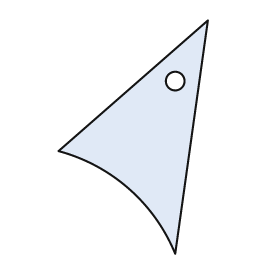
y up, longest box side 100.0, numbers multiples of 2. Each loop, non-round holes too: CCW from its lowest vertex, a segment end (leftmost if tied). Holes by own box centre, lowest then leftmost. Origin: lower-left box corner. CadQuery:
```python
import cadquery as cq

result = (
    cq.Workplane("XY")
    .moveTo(50.0, 0.0)
    .lineTo(64.0, 100.0)
    .lineTo(0.0, 44.0)
    .threePointArc((30.0, 28.0), (50.0, 0.0))
    .close()
    .moveTo(50.0, 74.0)
    .circle(4.0)
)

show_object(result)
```